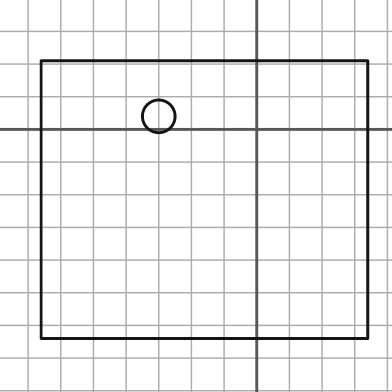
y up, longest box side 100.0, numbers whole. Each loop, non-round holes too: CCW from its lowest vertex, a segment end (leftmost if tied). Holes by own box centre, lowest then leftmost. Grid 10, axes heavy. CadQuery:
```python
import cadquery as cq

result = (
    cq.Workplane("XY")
    .moveTo(-66.0, -64.0)
    .lineTo(34.0, -64.0)
    .lineTo(34.0, 21.0)
    .lineTo(-66.0, 21.0)
    .close()
    .moveTo(-30.0, 4.0)
    .circle(5.0)
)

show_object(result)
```